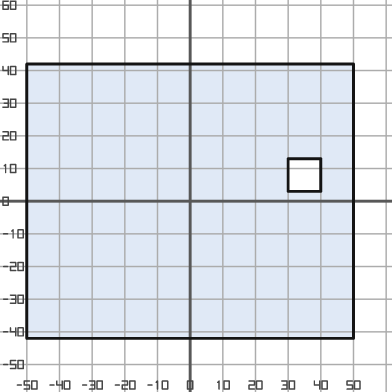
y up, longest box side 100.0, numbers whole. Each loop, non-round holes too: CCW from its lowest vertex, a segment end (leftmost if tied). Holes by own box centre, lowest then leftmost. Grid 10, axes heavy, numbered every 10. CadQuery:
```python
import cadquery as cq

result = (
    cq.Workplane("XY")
    .moveTo(-50.0, -42.0)
    .lineTo(50.0, -42.0)
    .lineTo(50.0, 42.0)
    .lineTo(-50.0, 42.0)
    .close()
    .moveTo(30.0, 3.0)
    .lineTo(40.0, 3.0)
    .lineTo(40.0, 13.0)
    .lineTo(30.0, 13.0)
    .close()
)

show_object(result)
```